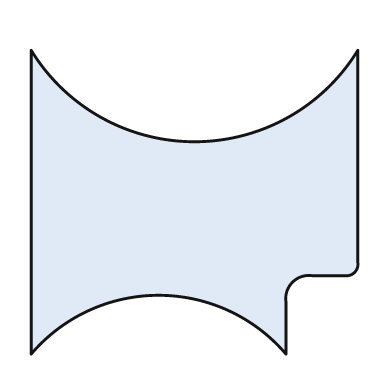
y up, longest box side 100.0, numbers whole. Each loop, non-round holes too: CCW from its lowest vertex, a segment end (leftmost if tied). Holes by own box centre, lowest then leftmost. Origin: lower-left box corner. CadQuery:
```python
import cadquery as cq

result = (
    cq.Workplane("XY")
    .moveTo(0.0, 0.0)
    .threePointArc((39.0, 18.0), (78.0, 0.0))
    .lineTo(78.0, 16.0)
    .threePointArc((80.0, 22.0), (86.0, 24.0))
    .lineTo(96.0, 24.0)
    .threePointArc((99.0, 25.0), (100.0, 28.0))
    .lineTo(100.0, 93.0)
    .threePointArc((50.0, 65.0), (0.0, 93.0))
    .close()
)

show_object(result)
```